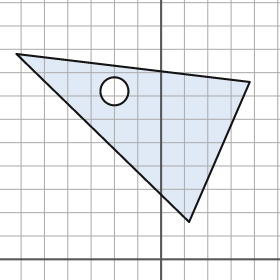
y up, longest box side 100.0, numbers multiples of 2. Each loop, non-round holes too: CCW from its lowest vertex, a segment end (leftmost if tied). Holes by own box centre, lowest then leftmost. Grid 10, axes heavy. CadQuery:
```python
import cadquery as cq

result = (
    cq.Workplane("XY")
    .moveTo(12.0, 16.0)
    .lineTo(38.0, 76.0)
    .lineTo(-62.0, 88.0)
    .close()
    .moveTo(-20.0, 72.0)
    .circle(6.0)
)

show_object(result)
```